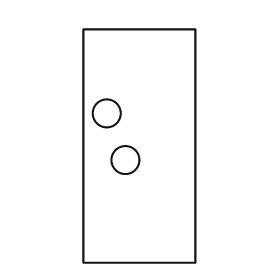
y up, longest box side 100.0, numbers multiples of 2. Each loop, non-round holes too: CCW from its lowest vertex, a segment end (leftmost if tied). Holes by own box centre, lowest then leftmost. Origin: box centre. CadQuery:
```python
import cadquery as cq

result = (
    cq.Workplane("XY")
    .moveTo(-24.0, -50.0)
    .lineTo(24.0, -50.0)
    .lineTo(24.0, 50.0)
    .lineTo(-24.0, 50.0)
    .close()
    .moveTo(-6.0, -6.0)
    .circle(6.0)
    .moveTo(-14.0, 14.0)
    .circle(6.0)
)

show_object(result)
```